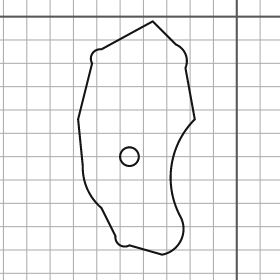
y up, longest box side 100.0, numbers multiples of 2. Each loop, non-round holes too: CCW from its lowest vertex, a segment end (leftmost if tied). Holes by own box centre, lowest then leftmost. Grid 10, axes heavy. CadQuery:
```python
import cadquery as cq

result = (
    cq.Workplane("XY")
    .moveTo(-32.0, -102.0)
    .threePointArc((-24.0, -96.0), (-24.0, -86.0))
    .threePointArc((-28.0, -64.0), (-18.0, -44.0))
    .lineTo(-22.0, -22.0)
    .threePointArc((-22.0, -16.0), (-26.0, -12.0))
    .lineTo(-36.0, -2.0)
    .lineTo(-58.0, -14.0)
    .threePointArc((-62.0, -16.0), (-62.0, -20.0))
    .lineTo(-68.0, -44.0)
    .lineTo(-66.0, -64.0)
    .threePointArc((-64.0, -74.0), (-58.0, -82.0))
    .lineTo(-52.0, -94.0)
    .threePointArc((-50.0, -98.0), (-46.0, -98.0))
    .close()
    .moveTo(-46.0, -60.0)
    .circle(4.0)
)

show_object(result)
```